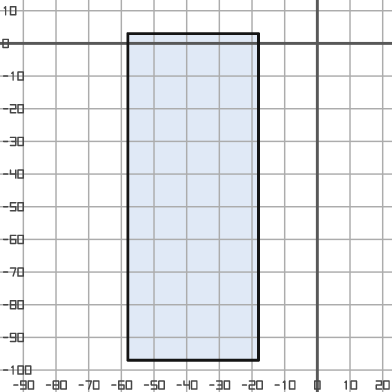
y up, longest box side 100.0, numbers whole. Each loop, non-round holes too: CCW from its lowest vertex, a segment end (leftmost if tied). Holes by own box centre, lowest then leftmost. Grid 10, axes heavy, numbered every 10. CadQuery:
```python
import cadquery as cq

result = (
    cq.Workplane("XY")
    .moveTo(-58.0, -97.0)
    .lineTo(-18.0, -97.0)
    .lineTo(-18.0, 3.0)
    .lineTo(-58.0, 3.0)
    .close()
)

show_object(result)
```